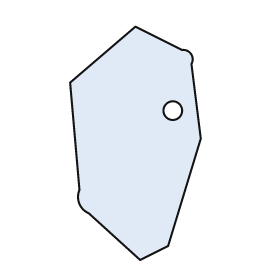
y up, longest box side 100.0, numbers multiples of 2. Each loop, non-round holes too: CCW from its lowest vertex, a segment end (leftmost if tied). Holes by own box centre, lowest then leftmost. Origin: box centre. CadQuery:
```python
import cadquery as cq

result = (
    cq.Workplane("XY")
    .moveTo(2.0, -50.0)
    .lineTo(14.0, -44.0)
    .lineTo(28.0, 2.0)
    .lineTo(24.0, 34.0)
    .threePointArc((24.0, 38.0), (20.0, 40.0))
    .lineTo(0.0, 50.0)
    .lineTo(-28.0, 26.0)
    .lineTo(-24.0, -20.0)
    .threePointArc((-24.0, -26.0), (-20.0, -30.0))
    .close()
    .moveTo(16.0, 14.0)
    .circle(4.0)
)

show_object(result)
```